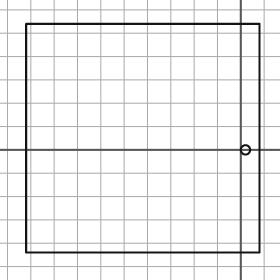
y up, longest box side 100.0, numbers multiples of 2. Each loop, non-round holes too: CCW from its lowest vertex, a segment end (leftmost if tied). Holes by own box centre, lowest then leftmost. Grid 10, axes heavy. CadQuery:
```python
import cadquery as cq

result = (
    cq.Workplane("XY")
    .moveTo(-92.0, -44.0)
    .lineTo(8.0, -44.0)
    .lineTo(8.0, 54.0)
    .lineTo(-92.0, 54.0)
    .close()
    .moveTo(2.0, 0.0)
    .circle(2.0)
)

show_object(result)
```